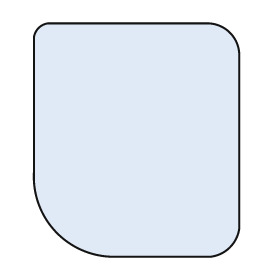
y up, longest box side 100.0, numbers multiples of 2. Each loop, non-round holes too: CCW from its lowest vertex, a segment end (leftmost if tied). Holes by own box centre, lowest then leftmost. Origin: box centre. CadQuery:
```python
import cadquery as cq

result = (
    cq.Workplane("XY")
    .moveTo(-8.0, -50.0)
    .lineTo(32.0, -50.0)
    .threePointArc((40.0, -46.0), (44.0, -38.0))
    .lineTo(44.0, 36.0)
    .threePointArc((40.0, 46.0), (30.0, 50.0))
    .lineTo(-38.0, 50.0)
    .threePointArc((-42.0, 48.0), (-44.0, 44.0))
    .lineTo(-44.0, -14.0)
    .threePointArc((-34.0, -40.0), (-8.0, -50.0))
    .close()
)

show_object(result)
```